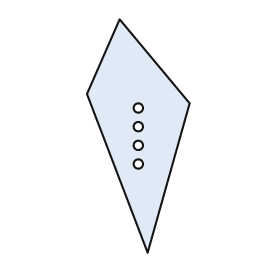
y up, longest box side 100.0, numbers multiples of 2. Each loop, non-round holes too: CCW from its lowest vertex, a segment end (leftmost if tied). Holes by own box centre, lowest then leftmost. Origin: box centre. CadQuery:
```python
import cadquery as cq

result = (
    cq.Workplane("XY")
    .moveTo(4.0, -50.0)
    .lineTo(22.0, 14.0)
    .lineTo(-8.0, 50.0)
    .lineTo(-22.0, 18.0)
    .close()
    .moveTo(0.0, -12.0)
    .circle(2.0)
    .moveTo(0.0, -4.0)
    .circle(2.0)
    .moveTo(0.0, 4.0)
    .circle(2.0)
    .moveTo(0.0, 12.0)
    .circle(2.0)
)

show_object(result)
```